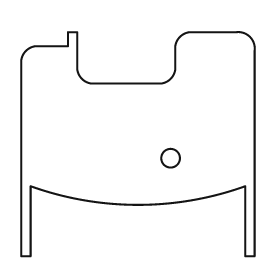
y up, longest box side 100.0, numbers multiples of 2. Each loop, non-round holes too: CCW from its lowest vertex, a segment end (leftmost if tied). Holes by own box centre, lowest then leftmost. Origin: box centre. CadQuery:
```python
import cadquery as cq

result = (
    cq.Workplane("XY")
    .moveTo(-50.0, -48.0)
    .lineTo(-46.0, -48.0)
    .lineTo(-46.0, -18.0)
    .threePointArc((0.0, -26.0), (46.0, -18.0))
    .lineTo(46.0, -48.0)
    .lineTo(50.0, -48.0)
    .lineTo(50.0, 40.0)
    .threePointArc((48.0, 46.0), (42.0, 48.0))
    .lineTo(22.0, 48.0)
    .threePointArc((18.0, 46.0), (16.0, 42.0))
    .lineTo(16.0, 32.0)
    .threePointArc((14.0, 28.0), (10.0, 26.0))
    .lineTo(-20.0, 26.0)
    .threePointArc((-24.0, 28.0), (-26.0, 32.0))
    .lineTo(-26.0, 48.0)
    .lineTo(-30.0, 48.0)
    .lineTo(-30.0, 42.0)
    .lineTo(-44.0, 42.0)
    .threePointArc((-48.0, 40.0), (-50.0, 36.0))
    .close()
    .moveTo(14.0, -6.0)
    .circle(4.0)
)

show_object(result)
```